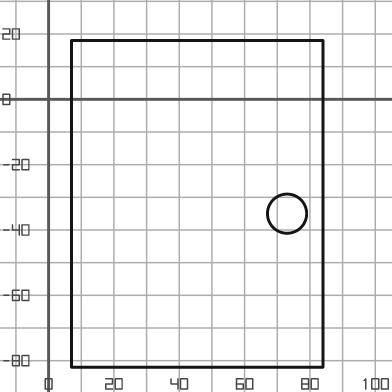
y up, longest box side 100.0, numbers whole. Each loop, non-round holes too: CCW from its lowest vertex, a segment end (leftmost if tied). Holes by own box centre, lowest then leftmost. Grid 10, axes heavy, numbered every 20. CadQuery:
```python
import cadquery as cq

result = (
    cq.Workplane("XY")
    .moveTo(7.0, -82.0)
    .lineTo(84.0, -82.0)
    .lineTo(84.0, 18.0)
    .lineTo(7.0, 18.0)
    .close()
    .moveTo(73.0, -35.0)
    .circle(6.0)
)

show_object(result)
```